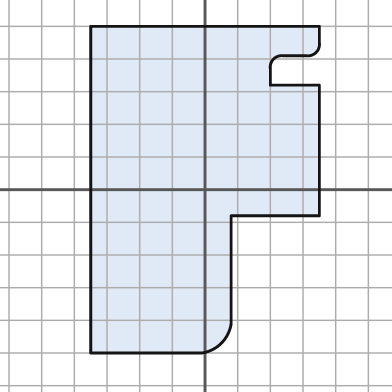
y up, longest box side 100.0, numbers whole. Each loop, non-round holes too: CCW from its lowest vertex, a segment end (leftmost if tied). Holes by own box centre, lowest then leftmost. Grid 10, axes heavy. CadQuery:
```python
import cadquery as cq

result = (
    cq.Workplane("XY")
    .moveTo(-35.0, -50.0)
    .lineTo(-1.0, -50.0)
    .threePointArc((5.0, -47.0), (8.0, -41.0))
    .lineTo(8.0, -8.0)
    .lineTo(35.0, -8.0)
    .lineTo(35.0, 32.0)
    .lineTo(20.0, 32.0)
    .lineTo(20.0, 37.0)
    .threePointArc((21.0, 40.0), (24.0, 41.0))
    .lineTo(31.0, 41.0)
    .threePointArc((34.0, 42.0), (35.0, 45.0))
    .lineTo(35.0, 50.0)
    .lineTo(-35.0, 50.0)
    .close()
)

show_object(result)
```